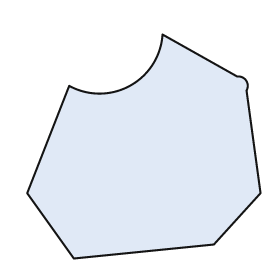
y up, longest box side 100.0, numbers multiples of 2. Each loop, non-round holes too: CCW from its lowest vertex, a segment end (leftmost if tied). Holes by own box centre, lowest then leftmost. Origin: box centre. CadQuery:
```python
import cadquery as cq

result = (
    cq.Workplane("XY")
    .moveTo(-30.0, -48.0)
    .lineTo(30.0, -42.0)
    .lineTo(50.0, -20.0)
    .lineTo(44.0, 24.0)
    .threePointArc((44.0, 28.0), (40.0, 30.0))
    .lineTo(8.0, 48.0)
    .threePointArc((-6.0, 26.0), (-32.0, 26.0))
    .lineTo(-50.0, -20.0)
    .close()
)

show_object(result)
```